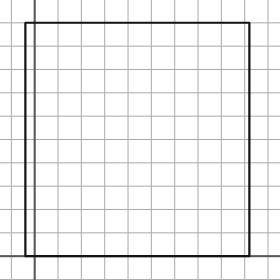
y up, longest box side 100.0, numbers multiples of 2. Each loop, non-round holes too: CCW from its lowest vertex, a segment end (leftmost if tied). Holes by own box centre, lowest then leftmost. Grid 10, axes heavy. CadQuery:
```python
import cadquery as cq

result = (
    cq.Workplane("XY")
    .moveTo(-4.0, 0.0)
    .lineTo(92.0, 0.0)
    .lineTo(92.0, 100.0)
    .lineTo(-4.0, 100.0)
    .close()
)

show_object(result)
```